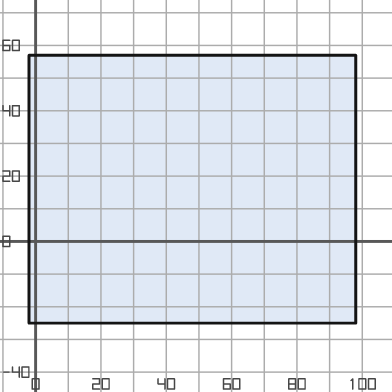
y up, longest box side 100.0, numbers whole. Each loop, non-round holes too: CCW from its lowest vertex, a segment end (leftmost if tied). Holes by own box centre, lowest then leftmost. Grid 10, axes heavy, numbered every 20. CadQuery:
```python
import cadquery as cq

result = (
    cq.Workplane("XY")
    .moveTo(-2.0, -25.0)
    .lineTo(98.0, -25.0)
    .lineTo(98.0, 57.0)
    .lineTo(-2.0, 57.0)
    .close()
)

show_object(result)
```